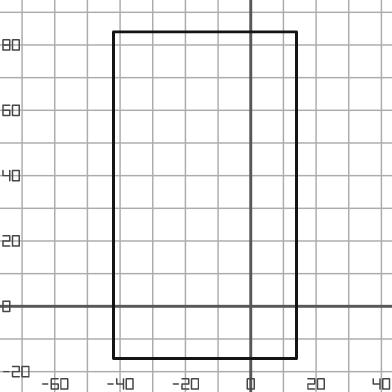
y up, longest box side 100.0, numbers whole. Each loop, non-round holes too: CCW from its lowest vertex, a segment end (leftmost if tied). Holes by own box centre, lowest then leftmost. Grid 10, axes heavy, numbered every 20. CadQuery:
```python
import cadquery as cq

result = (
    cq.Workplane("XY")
    .moveTo(-42.0, -16.0)
    .lineTo(14.0, -16.0)
    .lineTo(14.0, 84.0)
    .lineTo(-42.0, 84.0)
    .close()
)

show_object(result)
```